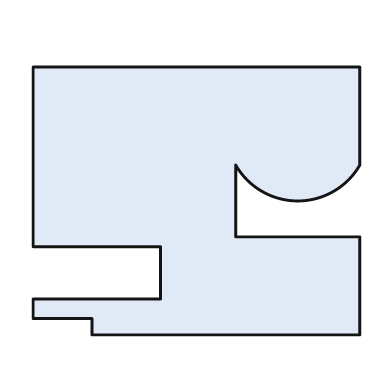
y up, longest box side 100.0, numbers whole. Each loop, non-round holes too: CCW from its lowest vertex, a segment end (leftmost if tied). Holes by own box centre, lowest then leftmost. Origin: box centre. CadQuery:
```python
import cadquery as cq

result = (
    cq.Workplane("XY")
    .moveTo(-32.0, -41.0)
    .lineTo(50.0, -41.0)
    .lineTo(50.0, -11.0)
    .lineTo(12.0, -11.0)
    .lineTo(12.0, 11.0)
    .threePointArc((31.0, 0.0), (50.0, 11.0))
    .lineTo(50.0, 41.0)
    .lineTo(-50.0, 41.0)
    .lineTo(-50.0, -14.0)
    .lineTo(-11.0, -14.0)
    .lineTo(-11.0, -30.0)
    .lineTo(-50.0, -30.0)
    .lineTo(-50.0, -36.0)
    .lineTo(-32.0, -36.0)
    .close()
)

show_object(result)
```